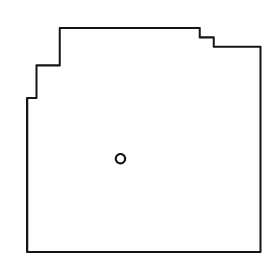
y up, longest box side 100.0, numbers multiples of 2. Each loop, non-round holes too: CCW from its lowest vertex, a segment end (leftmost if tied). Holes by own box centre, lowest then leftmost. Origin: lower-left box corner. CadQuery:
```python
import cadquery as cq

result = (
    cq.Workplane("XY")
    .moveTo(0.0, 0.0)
    .lineTo(100.0, 0.0)
    .lineTo(100.0, 88.0)
    .lineTo(80.0, 88.0)
    .lineTo(80.0, 92.0)
    .lineTo(74.0, 92.0)
    .lineTo(74.0, 96.0)
    .lineTo(14.0, 96.0)
    .lineTo(14.0, 80.0)
    .lineTo(4.0, 80.0)
    .lineTo(4.0, 66.0)
    .lineTo(0.0, 66.0)
    .close()
    .moveTo(40.0, 40.0)
    .circle(2.0)
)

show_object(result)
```